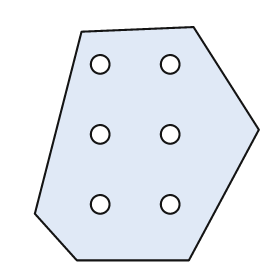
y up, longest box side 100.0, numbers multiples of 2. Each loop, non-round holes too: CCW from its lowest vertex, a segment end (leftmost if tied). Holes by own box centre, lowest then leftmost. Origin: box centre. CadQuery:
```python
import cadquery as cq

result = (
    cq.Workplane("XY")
    .moveTo(-30.0, -50.0)
    .lineTo(18.0, -50.0)
    .lineTo(48.0, 6.0)
    .lineTo(20.0, 50.0)
    .lineTo(-28.0, 48.0)
    .lineTo(-48.0, -30.0)
    .close()
    .moveTo(-20.0, -26.0)
    .circle(4.0)
    .moveTo(10.0, -26.0)
    .circle(4.0)
    .moveTo(-20.0, 4.0)
    .circle(4.0)
    .moveTo(10.0, 4.0)
    .circle(4.0)
    .moveTo(-20.0, 34.0)
    .circle(4.0)
    .moveTo(10.0, 34.0)
    .circle(4.0)
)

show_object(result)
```